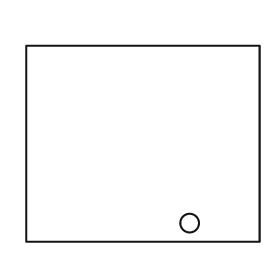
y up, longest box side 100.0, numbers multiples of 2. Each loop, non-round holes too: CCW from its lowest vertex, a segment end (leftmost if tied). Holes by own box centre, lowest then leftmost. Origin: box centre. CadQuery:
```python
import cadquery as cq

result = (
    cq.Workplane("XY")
    .moveTo(-50.0, -42.0)
    .lineTo(50.0, -42.0)
    .lineTo(50.0, 42.0)
    .lineTo(-50.0, 42.0)
    .close()
    .moveTo(20.0, -34.0)
    .circle(4.0)
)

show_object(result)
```